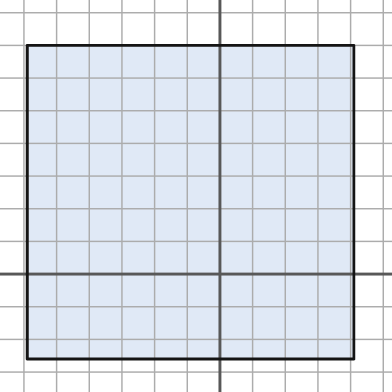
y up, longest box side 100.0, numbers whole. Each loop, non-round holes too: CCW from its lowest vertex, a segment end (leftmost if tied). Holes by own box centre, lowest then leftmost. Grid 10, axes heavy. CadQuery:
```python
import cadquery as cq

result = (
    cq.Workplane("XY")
    .moveTo(-59.0, -26.0)
    .lineTo(41.0, -26.0)
    .lineTo(41.0, 70.0)
    .lineTo(-59.0, 70.0)
    .close()
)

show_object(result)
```